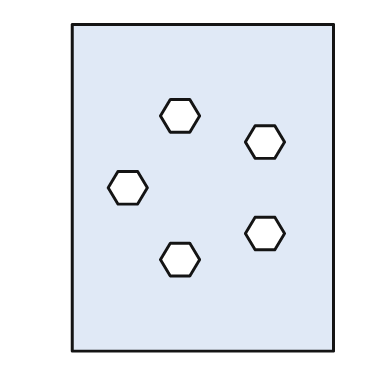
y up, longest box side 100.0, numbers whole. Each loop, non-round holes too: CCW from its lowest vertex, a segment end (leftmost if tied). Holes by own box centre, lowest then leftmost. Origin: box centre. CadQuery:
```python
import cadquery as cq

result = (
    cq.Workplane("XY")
    .moveTo(-40.0, -50.0)
    .lineTo(40.0, -50.0)
    .lineTo(40.0, 50.0)
    .lineTo(-40.0, 50.0)
    .close()
    .moveTo(-10.0, -27.0)
    .lineTo(-4.0, -27.0)
    .lineTo(-1.0, -22.0)
    .lineTo(-4.0, -17.0)
    .lineTo(-10.0, -17.0)
    .lineTo(-13.0, -22.0)
    .close()
    .moveTo(16.0, -19.0)
    .lineTo(22.0, -19.0)
    .lineTo(25.0, -14.0)
    .lineTo(22.0, -9.0)
    .lineTo(16.0, -9.0)
    .lineTo(13.0, -14.0)
    .close()
    .moveTo(-26.0, -5.0)
    .lineTo(-20.0, -5.0)
    .lineTo(-17.0, 0.0)
    .lineTo(-20.0, 5.0)
    .lineTo(-26.0, 5.0)
    .lineTo(-29.0, 0.0)
    .close()
    .moveTo(16.0, 9.0)
    .lineTo(22.0, 9.0)
    .lineTo(25.0, 14.0)
    .lineTo(22.0, 19.0)
    .lineTo(16.0, 19.0)
    .lineTo(13.0, 14.0)
    .close()
    .moveTo(-10.0, 17.0)
    .lineTo(-4.0, 17.0)
    .lineTo(-1.0, 22.0)
    .lineTo(-4.0, 27.0)
    .lineTo(-10.0, 27.0)
    .lineTo(-13.0, 22.0)
    .close()
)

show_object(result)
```